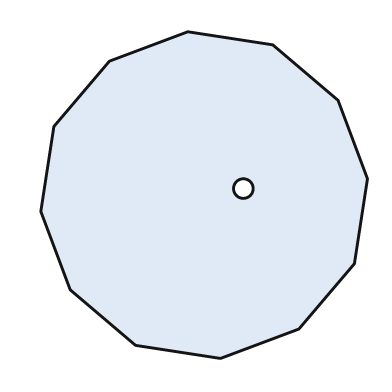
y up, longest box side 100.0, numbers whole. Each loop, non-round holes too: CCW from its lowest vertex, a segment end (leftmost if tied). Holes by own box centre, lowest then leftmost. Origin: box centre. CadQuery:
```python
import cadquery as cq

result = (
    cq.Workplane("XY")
    .moveTo(5.0, -50.0)
    .lineTo(29.0, -41.0)
    .lineTo(46.0, -21.0)
    .lineTo(50.0, 5.0)
    .lineTo(41.0, 29.0)
    .lineTo(21.0, 46.0)
    .lineTo(-5.0, 50.0)
    .lineTo(-29.0, 41.0)
    .lineTo(-46.0, 21.0)
    .lineTo(-50.0, -5.0)
    .lineTo(-41.0, -29.0)
    .lineTo(-21.0, -46.0)
    .close()
    .moveTo(12.0, 2.0)
    .circle(3.0)
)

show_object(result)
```